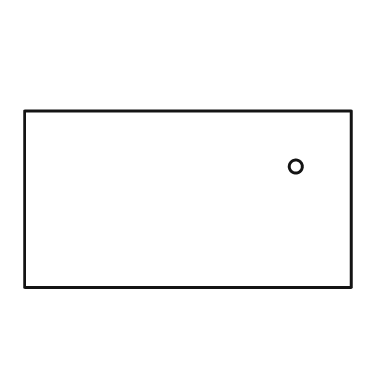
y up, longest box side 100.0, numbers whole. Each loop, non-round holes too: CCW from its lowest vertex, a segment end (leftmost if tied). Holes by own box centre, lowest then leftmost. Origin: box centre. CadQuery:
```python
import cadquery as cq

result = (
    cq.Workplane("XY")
    .moveTo(-50.0, -27.0)
    .lineTo(50.0, -27.0)
    .lineTo(50.0, 27.0)
    .lineTo(-50.0, 27.0)
    .close()
    .moveTo(33.0, 10.0)
    .circle(2.0)
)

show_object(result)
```